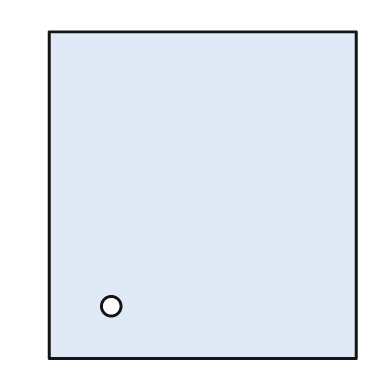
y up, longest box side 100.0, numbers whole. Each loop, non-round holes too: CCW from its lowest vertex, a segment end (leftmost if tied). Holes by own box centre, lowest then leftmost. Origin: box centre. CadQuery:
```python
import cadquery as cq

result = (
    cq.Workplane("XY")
    .moveTo(-47.0, -50.0)
    .lineTo(47.0, -50.0)
    .lineTo(47.0, 50.0)
    .lineTo(-47.0, 50.0)
    .close()
    .moveTo(-28.0, -34.0)
    .circle(3.0)
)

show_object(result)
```